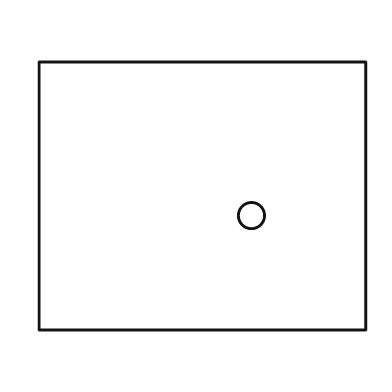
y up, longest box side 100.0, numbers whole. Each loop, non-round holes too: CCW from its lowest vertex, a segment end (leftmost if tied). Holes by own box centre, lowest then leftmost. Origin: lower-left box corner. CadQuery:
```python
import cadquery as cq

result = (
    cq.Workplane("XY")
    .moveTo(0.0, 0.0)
    .lineTo(100.0, 0.0)
    .lineTo(100.0, 82.0)
    .lineTo(0.0, 82.0)
    .close()
    .moveTo(65.0, 35.0)
    .circle(4.0)
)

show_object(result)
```